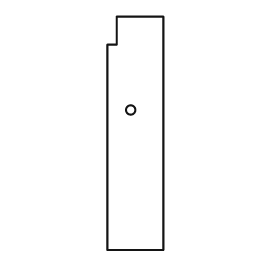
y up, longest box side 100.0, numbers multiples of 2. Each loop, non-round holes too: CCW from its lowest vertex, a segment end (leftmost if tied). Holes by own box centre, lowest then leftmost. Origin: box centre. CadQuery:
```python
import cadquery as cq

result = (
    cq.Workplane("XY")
    .moveTo(-12.0, -50.0)
    .lineTo(12.0, -50.0)
    .lineTo(12.0, 50.0)
    .lineTo(-8.0, 50.0)
    .lineTo(-8.0, 38.0)
    .lineTo(-12.0, 38.0)
    .close()
    .moveTo(-2.0, 10.0)
    .circle(2.0)
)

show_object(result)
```